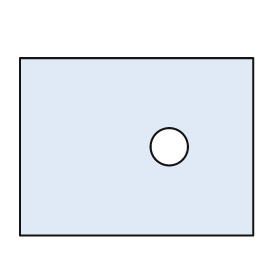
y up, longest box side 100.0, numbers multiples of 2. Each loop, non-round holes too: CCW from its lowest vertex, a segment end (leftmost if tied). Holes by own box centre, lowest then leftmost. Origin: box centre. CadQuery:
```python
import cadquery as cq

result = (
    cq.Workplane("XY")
    .moveTo(-50.0, -38.0)
    .lineTo(50.0, -38.0)
    .lineTo(50.0, 38.0)
    .lineTo(-50.0, 38.0)
    .close()
    .moveTo(14.0, 0.0)
    .circle(8.0)
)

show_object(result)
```